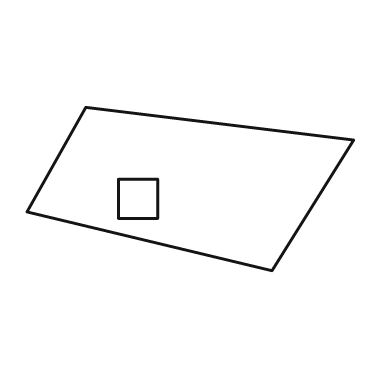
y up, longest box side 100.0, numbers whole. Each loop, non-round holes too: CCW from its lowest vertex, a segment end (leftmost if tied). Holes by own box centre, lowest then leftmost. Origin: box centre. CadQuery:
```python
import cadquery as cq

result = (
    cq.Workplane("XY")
    .moveTo(25.0, -25.0)
    .lineTo(50.0, 15.0)
    .lineTo(-32.0, 25.0)
    .lineTo(-50.0, -7.0)
    .close()
    .moveTo(-22.0, -9.0)
    .lineTo(-10.0, -9.0)
    .lineTo(-10.0, 3.0)
    .lineTo(-22.0, 3.0)
    .close()
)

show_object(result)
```